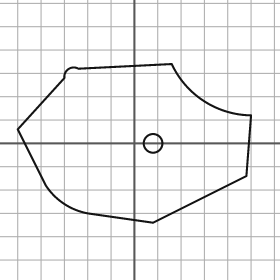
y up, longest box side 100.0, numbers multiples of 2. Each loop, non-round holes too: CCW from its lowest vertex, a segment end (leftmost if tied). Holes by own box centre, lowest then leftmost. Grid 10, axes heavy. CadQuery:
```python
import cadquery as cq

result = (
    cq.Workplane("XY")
    .moveTo(8.0, -34.0)
    .lineTo(48.0, -14.0)
    .lineTo(50.0, 12.0)
    .threePointArc((30.0, 18.0), (16.0, 34.0))
    .lineTo(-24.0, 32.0)
    .threePointArc((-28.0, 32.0), (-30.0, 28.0))
    .lineTo(-50.0, 6.0)
    .lineTo(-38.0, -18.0)
    .threePointArc((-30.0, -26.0), (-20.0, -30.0))
    .close()
    .moveTo(8.0, 0.0)
    .circle(4.0)
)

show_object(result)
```